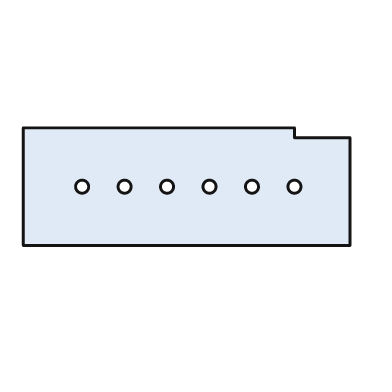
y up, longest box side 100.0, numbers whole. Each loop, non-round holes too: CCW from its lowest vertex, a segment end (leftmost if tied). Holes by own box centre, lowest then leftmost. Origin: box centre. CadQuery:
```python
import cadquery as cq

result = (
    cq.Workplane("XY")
    .moveTo(-50.0, -18.0)
    .lineTo(50.0, -18.0)
    .lineTo(50.0, 15.0)
    .lineTo(33.0, 15.0)
    .lineTo(33.0, 18.0)
    .lineTo(-50.0, 18.0)
    .close()
    .moveTo(-32.0, 0.0)
    .circle(2.0)
    .moveTo(-19.0, 0.0)
    .circle(2.0)
    .moveTo(-6.0, 0.0)
    .circle(2.0)
    .moveTo(7.0, 0.0)
    .circle(2.0)
    .moveTo(20.0, 0.0)
    .circle(2.0)
    .moveTo(33.0, 0.0)
    .circle(2.0)
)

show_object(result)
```